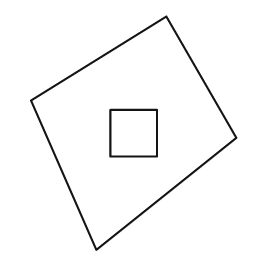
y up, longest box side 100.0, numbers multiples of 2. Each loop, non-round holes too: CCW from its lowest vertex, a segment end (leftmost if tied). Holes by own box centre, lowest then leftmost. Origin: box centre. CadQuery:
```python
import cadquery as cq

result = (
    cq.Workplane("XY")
    .moveTo(-16.0, -50.0)
    .lineTo(44.0, -2.0)
    .lineTo(14.0, 50.0)
    .lineTo(-44.0, 14.0)
    .close()
    .moveTo(-10.0, -10.0)
    .lineTo(10.0, -10.0)
    .lineTo(10.0, 10.0)
    .lineTo(-10.0, 10.0)
    .close()
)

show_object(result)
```